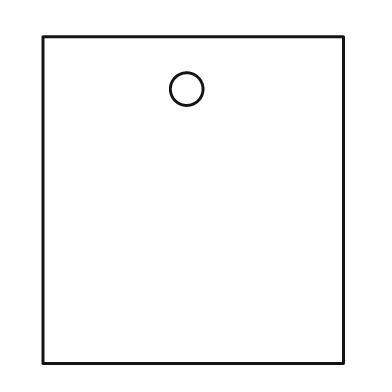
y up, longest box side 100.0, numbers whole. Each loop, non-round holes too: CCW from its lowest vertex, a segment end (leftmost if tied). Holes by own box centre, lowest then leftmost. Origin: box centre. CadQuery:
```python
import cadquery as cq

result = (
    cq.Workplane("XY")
    .moveTo(-46.0, -50.0)
    .lineTo(46.0, -50.0)
    .lineTo(46.0, 50.0)
    .lineTo(-46.0, 50.0)
    .close()
    .moveTo(-2.0, 34.0)
    .circle(5.0)
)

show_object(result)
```